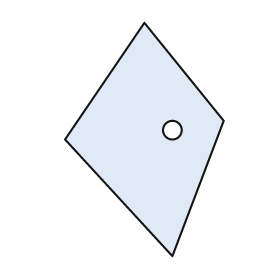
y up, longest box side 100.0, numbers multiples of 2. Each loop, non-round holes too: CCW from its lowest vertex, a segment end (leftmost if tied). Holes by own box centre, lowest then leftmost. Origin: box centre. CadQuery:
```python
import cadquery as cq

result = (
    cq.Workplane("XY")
    .moveTo(12.0, -50.0)
    .lineTo(34.0, 8.0)
    .lineTo(0.0, 50.0)
    .lineTo(-34.0, 0.0)
    .close()
    .moveTo(12.0, 4.0)
    .circle(4.0)
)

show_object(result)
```